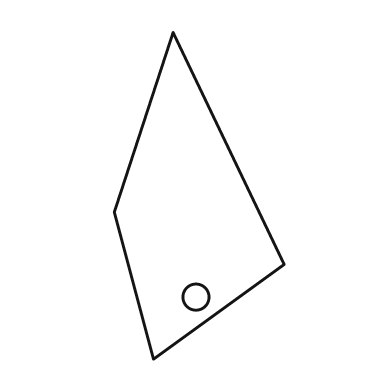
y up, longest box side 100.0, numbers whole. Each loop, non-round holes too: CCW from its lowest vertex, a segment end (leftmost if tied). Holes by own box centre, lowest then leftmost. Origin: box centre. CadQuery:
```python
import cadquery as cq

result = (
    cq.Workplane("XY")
    .moveTo(-14.0, -50.0)
    .lineTo(26.0, -21.0)
    .lineTo(-8.0, 50.0)
    .lineTo(-26.0, -5.0)
    .close()
    .moveTo(-1.0, -31.0)
    .circle(4.0)
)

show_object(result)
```